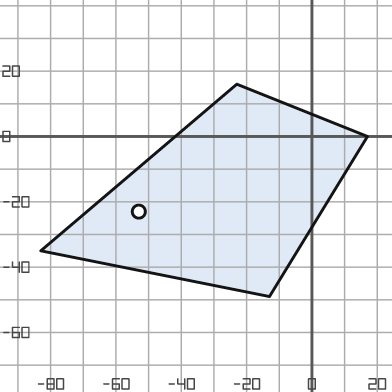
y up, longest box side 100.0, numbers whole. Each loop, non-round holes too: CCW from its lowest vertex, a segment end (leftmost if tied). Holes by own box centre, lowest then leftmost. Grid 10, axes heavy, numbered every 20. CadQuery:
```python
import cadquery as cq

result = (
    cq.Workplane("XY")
    .moveTo(-13.0, -49.0)
    .lineTo(17.0, 0.0)
    .lineTo(-23.0, 16.0)
    .lineTo(-83.0, -35.0)
    .close()
    .moveTo(-53.0, -23.0)
    .circle(2.0)
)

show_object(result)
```